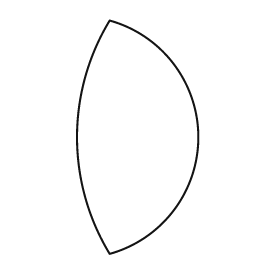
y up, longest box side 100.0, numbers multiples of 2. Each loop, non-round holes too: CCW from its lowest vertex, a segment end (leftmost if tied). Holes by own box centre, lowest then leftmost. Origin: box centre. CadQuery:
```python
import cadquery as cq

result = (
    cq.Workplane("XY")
    .moveTo(-12.0, -50.0)
    .threePointArc((26.0, 0.0), (-12.0, 50.0))
    .threePointArc((-26.0, 0.0), (-12.0, -50.0))
    .close()
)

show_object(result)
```